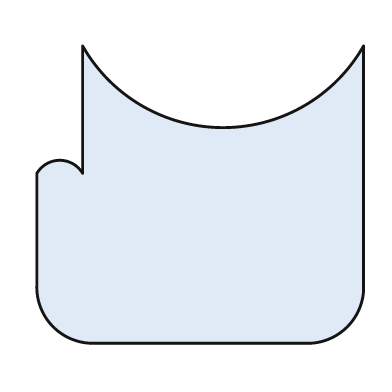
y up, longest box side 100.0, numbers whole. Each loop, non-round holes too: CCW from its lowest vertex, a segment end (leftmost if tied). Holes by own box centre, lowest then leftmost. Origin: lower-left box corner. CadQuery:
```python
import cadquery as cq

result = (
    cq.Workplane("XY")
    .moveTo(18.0, 0.0)
    .lineTo(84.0, 0.0)
    .threePointArc((95.0, 5.0), (100.0, 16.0))
    .lineTo(100.0, 91.0)
    .threePointArc((57.0, 66.0), (14.0, 91.0))
    .lineTo(14.0, 52.0)
    .threePointArc((7.0, 56.0), (0.0, 52.0))
    .lineTo(0.0, 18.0)
    .threePointArc((5.0, 5.0), (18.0, 0.0))
    .close()
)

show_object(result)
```